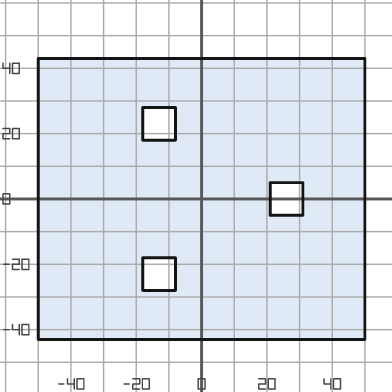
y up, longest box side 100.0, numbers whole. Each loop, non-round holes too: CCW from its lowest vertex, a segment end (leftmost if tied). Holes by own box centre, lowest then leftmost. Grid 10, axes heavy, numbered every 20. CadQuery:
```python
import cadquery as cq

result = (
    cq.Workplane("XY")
    .moveTo(-50.0, -43.0)
    .lineTo(50.0, -43.0)
    .lineTo(50.0, 43.0)
    .lineTo(-50.0, 43.0)
    .close()
    .moveTo(-18.0, -28.0)
    .lineTo(-8.0, -28.0)
    .lineTo(-8.0, -18.0)
    .lineTo(-18.0, -18.0)
    .close()
    .moveTo(21.0, -5.0)
    .lineTo(31.0, -5.0)
    .lineTo(31.0, 5.0)
    .lineTo(21.0, 5.0)
    .close()
    .moveTo(-18.0, 18.0)
    .lineTo(-8.0, 18.0)
    .lineTo(-8.0, 28.0)
    .lineTo(-18.0, 28.0)
    .close()
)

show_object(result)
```